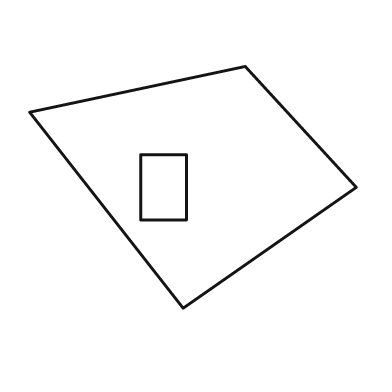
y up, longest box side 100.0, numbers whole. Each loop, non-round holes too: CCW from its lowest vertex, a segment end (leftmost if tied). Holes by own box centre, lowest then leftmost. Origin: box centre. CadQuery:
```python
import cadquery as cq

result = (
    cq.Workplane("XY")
    .moveTo(-3.0, -37.0)
    .lineTo(50.0, 0.0)
    .lineTo(16.0, 37.0)
    .lineTo(-50.0, 23.0)
    .close()
    .moveTo(-16.0, -10.0)
    .lineTo(-2.0, -10.0)
    .lineTo(-2.0, 10.0)
    .lineTo(-16.0, 10.0)
    .close()
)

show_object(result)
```